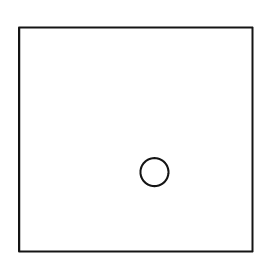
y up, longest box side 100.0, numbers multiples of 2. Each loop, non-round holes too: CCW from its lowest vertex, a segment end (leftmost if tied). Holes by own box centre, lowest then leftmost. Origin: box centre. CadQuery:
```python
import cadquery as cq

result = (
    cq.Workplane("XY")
    .moveTo(-50.0, -48.0)
    .lineTo(50.0, -48.0)
    .lineTo(50.0, 48.0)
    .lineTo(-50.0, 48.0)
    .close()
    .moveTo(8.0, -14.0)
    .circle(6.0)
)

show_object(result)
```